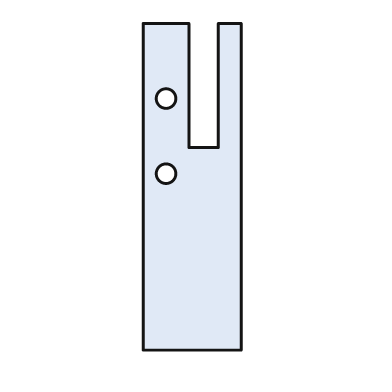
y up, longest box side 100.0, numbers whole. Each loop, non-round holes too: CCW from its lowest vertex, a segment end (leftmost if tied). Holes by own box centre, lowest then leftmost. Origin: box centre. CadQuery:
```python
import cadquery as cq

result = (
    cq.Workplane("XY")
    .moveTo(-15.0, -50.0)
    .lineTo(15.0, -50.0)
    .lineTo(15.0, 50.0)
    .lineTo(8.0, 50.0)
    .lineTo(8.0, 12.0)
    .lineTo(-1.0, 12.0)
    .lineTo(-1.0, 50.0)
    .lineTo(-15.0, 50.0)
    .close()
    .moveTo(-8.0, 4.0)
    .circle(3.0)
    .moveTo(-8.0, 27.0)
    .circle(3.0)
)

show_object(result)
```